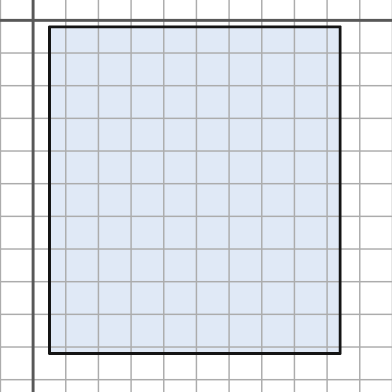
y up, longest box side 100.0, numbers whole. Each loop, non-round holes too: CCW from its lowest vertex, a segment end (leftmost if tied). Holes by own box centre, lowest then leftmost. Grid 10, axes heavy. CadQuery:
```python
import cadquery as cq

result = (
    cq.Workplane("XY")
    .moveTo(5.0, -102.0)
    .lineTo(94.0, -102.0)
    .lineTo(94.0, -2.0)
    .lineTo(5.0, -2.0)
    .close()
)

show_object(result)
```